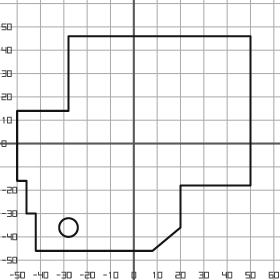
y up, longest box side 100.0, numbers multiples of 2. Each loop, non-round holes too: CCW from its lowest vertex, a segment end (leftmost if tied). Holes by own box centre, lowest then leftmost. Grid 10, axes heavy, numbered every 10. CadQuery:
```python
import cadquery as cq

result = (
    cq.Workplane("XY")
    .moveTo(-42.0, -46.0)
    .lineTo(8.0, -46.0)
    .lineTo(20.0, -36.0)
    .lineTo(20.0, -18.0)
    .lineTo(50.0, -18.0)
    .lineTo(50.0, 46.0)
    .lineTo(-28.0, 46.0)
    .lineTo(-28.0, 14.0)
    .lineTo(-50.0, 14.0)
    .lineTo(-50.0, -16.0)
    .lineTo(-46.0, -16.0)
    .lineTo(-46.0, -30.0)
    .lineTo(-42.0, -30.0)
    .close()
    .moveTo(-28.0, -36.0)
    .circle(4.0)
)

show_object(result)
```